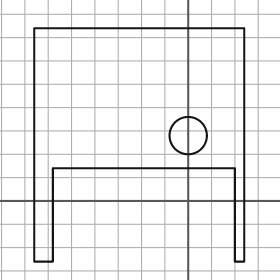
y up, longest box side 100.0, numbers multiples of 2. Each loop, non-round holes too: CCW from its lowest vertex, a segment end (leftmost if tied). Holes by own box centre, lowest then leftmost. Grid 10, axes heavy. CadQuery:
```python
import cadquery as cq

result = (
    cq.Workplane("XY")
    .moveTo(-66.0, -26.0)
    .lineTo(-58.0, -26.0)
    .lineTo(-58.0, 14.0)
    .lineTo(20.0, 14.0)
    .lineTo(20.0, -26.0)
    .lineTo(24.0, -26.0)
    .lineTo(24.0, 74.0)
    .lineTo(-66.0, 74.0)
    .close()
    .moveTo(0.0, 28.0)
    .circle(8.0)
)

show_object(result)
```